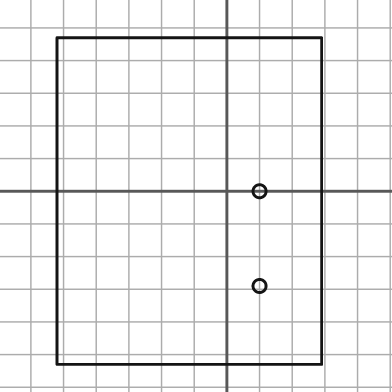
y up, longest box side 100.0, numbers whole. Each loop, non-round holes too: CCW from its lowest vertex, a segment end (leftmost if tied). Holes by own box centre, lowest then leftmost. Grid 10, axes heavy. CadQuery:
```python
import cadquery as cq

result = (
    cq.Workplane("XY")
    .moveTo(-52.0, -53.0)
    .lineTo(29.0, -53.0)
    .lineTo(29.0, 47.0)
    .lineTo(-52.0, 47.0)
    .close()
    .moveTo(10.0, -29.0)
    .circle(2.0)
    .moveTo(10.0, 0.0)
    .circle(2.0)
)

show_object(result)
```